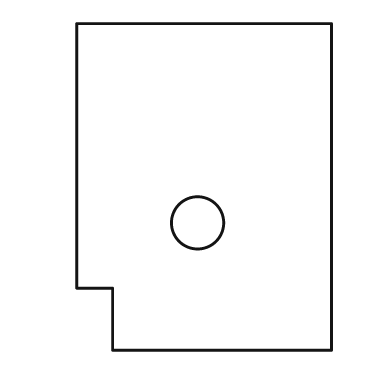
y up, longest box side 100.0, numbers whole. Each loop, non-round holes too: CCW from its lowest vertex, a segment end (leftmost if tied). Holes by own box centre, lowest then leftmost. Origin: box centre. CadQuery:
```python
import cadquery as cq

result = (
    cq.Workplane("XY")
    .moveTo(-28.0, -50.0)
    .lineTo(39.0, -50.0)
    .lineTo(39.0, 50.0)
    .lineTo(-39.0, 50.0)
    .lineTo(-39.0, -31.0)
    .lineTo(-28.0, -31.0)
    .close()
    .moveTo(-2.0, -11.0)
    .circle(8.0)
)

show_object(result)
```